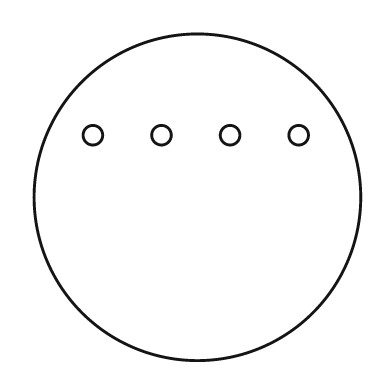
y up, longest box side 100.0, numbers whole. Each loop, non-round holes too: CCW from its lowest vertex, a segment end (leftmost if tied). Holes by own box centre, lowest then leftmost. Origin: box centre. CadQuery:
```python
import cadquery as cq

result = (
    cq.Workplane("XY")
    .moveTo(0.0, 0.0)
    .circle(50.0)
    .moveTo(-32.0, 19.0)
    .circle(3.0)
    .moveTo(-11.0, 19.0)
    .circle(3.0)
    .moveTo(10.0, 19.0)
    .circle(3.0)
    .moveTo(31.0, 19.0)
    .circle(3.0)
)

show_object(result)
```